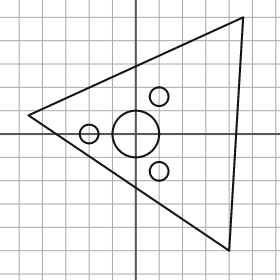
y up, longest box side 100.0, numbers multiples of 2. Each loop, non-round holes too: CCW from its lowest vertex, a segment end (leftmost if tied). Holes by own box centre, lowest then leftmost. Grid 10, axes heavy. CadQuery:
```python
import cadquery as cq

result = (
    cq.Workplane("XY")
    .moveTo(40.0, -50.0)
    .lineTo(46.0, 50.0)
    .lineTo(-46.0, 8.0)
    .close()
    .moveTo(10.0, -16.0)
    .circle(4.0)
    .moveTo(-20.0, 0.0)
    .circle(4.0)
    .moveTo(0.0, 0.0)
    .circle(10.0)
    .moveTo(10.0, 16.0)
    .circle(4.0)
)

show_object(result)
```